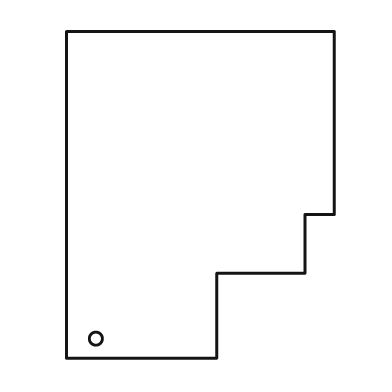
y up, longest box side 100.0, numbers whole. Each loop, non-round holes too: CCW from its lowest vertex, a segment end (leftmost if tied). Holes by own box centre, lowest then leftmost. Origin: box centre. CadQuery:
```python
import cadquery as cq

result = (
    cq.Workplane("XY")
    .moveTo(-41.0, -50.0)
    .lineTo(5.0, -50.0)
    .lineTo(5.0, -24.0)
    .lineTo(32.0, -24.0)
    .lineTo(32.0, -6.0)
    .lineTo(41.0, -6.0)
    .lineTo(41.0, 50.0)
    .lineTo(-41.0, 50.0)
    .close()
    .moveTo(-32.0, -44.0)
    .circle(2.0)
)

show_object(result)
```